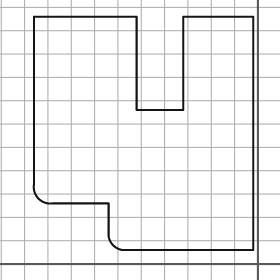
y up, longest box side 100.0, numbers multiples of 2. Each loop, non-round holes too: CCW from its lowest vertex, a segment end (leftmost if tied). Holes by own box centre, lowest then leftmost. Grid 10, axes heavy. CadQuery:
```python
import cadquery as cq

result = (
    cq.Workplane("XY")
    .moveTo(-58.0, 6.0)
    .lineTo(-2.0, 6.0)
    .lineTo(-2.0, 106.0)
    .lineTo(-32.0, 106.0)
    .lineTo(-32.0, 66.0)
    .lineTo(-52.0, 66.0)
    .lineTo(-52.0, 106.0)
    .lineTo(-96.0, 106.0)
    .lineTo(-96.0, 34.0)
    .threePointArc((-94.0, 28.0), (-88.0, 26.0))
    .lineTo(-64.0, 26.0)
    .lineTo(-64.0, 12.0)
    .threePointArc((-62.0, 8.0), (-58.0, 6.0))
    .close()
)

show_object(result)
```